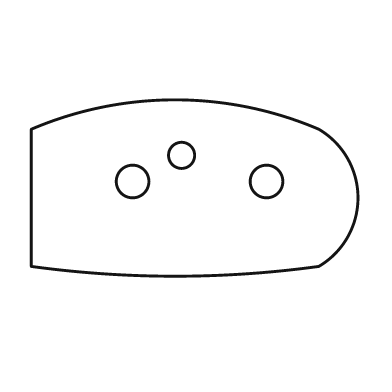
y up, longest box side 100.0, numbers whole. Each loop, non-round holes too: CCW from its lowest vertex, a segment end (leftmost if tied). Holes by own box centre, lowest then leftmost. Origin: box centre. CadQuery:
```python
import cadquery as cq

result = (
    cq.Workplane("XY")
    .moveTo(-50.0, -24.0)
    .threePointArc((-6.0, -27.0), (38.0, -24.0))
    .threePointArc((50.0, -3.0), (38.0, 18.0))
    .threePointArc((-6.0, 27.0), (-50.0, 18.0))
    .close()
    .moveTo(-19.0, 2.0)
    .circle(5.0)
    .moveTo(22.0, 2.0)
    .circle(5.0)
    .moveTo(-4.0, 10.0)
    .circle(4.0)
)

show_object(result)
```